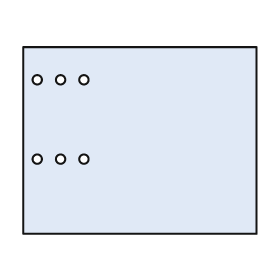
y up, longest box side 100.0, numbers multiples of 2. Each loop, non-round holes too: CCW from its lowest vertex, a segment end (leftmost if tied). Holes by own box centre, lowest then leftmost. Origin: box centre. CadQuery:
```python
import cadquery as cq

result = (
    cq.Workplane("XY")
    .moveTo(-50.0, -40.0)
    .lineTo(50.0, -40.0)
    .lineTo(50.0, 40.0)
    .lineTo(-50.0, 40.0)
    .close()
    .moveTo(-44.0, -8.0)
    .circle(2.0)
    .moveTo(-34.0, -8.0)
    .circle(2.0)
    .moveTo(-24.0, -8.0)
    .circle(2.0)
    .moveTo(-44.0, 26.0)
    .circle(2.0)
    .moveTo(-34.0, 26.0)
    .circle(2.0)
    .moveTo(-24.0, 26.0)
    .circle(2.0)
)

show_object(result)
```